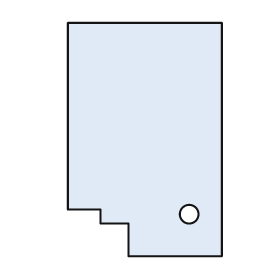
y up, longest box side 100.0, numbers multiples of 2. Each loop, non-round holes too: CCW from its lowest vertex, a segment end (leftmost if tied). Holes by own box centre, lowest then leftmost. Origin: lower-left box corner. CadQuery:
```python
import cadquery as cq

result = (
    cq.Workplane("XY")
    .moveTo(26.0, 0.0)
    .lineTo(66.0, 0.0)
    .lineTo(66.0, 100.0)
    .lineTo(0.0, 100.0)
    .lineTo(0.0, 20.0)
    .lineTo(14.0, 20.0)
    .lineTo(14.0, 14.0)
    .lineTo(26.0, 14.0)
    .close()
    .moveTo(52.0, 18.0)
    .circle(4.0)
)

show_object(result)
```